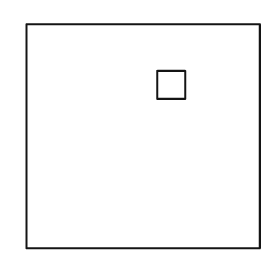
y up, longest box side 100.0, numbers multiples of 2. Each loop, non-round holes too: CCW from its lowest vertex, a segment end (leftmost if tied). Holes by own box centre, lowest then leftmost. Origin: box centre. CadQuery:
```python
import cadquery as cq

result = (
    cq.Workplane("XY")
    .moveTo(-50.0, -48.0)
    .lineTo(50.0, -48.0)
    .lineTo(50.0, 48.0)
    .lineTo(-50.0, 48.0)
    .close()
    .moveTo(6.0, 16.0)
    .lineTo(18.0, 16.0)
    .lineTo(18.0, 28.0)
    .lineTo(6.0, 28.0)
    .close()
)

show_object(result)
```